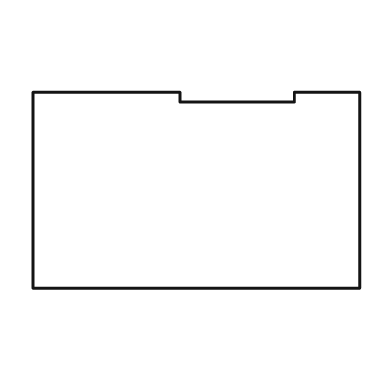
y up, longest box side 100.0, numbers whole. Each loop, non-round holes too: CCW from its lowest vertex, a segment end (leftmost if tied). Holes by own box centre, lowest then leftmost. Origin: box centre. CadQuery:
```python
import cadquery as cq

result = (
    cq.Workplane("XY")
    .moveTo(-50.0, -30.0)
    .lineTo(50.0, -30.0)
    .lineTo(50.0, 30.0)
    .lineTo(30.0, 30.0)
    .lineTo(30.0, 27.0)
    .lineTo(-5.0, 27.0)
    .lineTo(-5.0, 30.0)
    .lineTo(-50.0, 30.0)
    .close()
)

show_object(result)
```